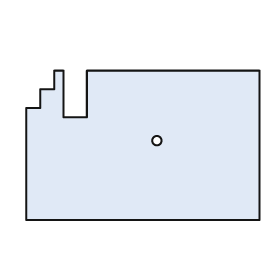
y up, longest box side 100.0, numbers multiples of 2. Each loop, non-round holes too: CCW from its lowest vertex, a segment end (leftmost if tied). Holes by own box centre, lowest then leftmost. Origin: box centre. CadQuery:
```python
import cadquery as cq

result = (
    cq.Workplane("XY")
    .moveTo(-50.0, -32.0)
    .lineTo(50.0, -32.0)
    .lineTo(50.0, 32.0)
    .lineTo(-24.0, 32.0)
    .lineTo(-24.0, 12.0)
    .lineTo(-34.0, 12.0)
    .lineTo(-34.0, 32.0)
    .lineTo(-38.0, 32.0)
    .lineTo(-38.0, 24.0)
    .lineTo(-44.0, 24.0)
    .lineTo(-44.0, 16.0)
    .lineTo(-50.0, 16.0)
    .close()
    .moveTo(6.0, 2.0)
    .circle(2.0)
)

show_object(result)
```